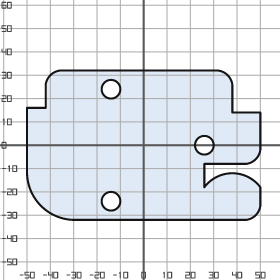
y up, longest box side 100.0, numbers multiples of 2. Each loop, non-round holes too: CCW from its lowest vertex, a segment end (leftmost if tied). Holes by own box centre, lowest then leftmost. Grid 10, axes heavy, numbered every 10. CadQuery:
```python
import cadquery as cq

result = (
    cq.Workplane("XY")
    .moveTo(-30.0, -32.0)
    .lineTo(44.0, -32.0)
    .threePointArc((48.0, -30.0), (50.0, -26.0))
    .lineTo(50.0, -18.0)
    .threePointArc((38.0, -12.0), (26.0, -18.0))
    .lineTo(26.0, -8.0)
    .lineTo(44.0, -8.0)
    .threePointArc((48.0, -6.0), (50.0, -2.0))
    .lineTo(50.0, 14.0)
    .lineTo(38.0, 14.0)
    .lineTo(38.0, 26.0)
    .threePointArc((36.0, 30.0), (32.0, 32.0))
    .lineTo(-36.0, 32.0)
    .threePointArc((-40.0, 30.0), (-42.0, 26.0))
    .lineTo(-42.0, 16.0)
    .lineTo(-50.0, 16.0)
    .lineTo(-50.0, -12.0)
    .threePointArc((-44.0, -26.0), (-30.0, -32.0))
    .close()
    .moveTo(-14.0, -24.0)
    .circle(4.0)
    .moveTo(26.0, 0.0)
    .circle(4.0)
    .moveTo(-14.0, 24.0)
    .circle(4.0)
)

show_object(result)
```